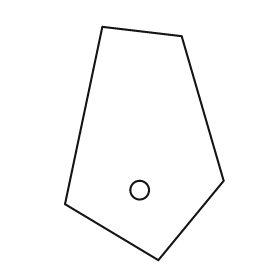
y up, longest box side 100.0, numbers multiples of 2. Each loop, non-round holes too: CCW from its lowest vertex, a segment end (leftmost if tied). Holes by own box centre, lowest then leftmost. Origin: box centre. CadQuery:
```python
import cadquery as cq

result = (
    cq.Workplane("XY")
    .moveTo(6.0, -50.0)
    .lineTo(34.0, -16.0)
    .lineTo(16.0, 46.0)
    .lineTo(-18.0, 50.0)
    .lineTo(-34.0, -26.0)
    .close()
    .moveTo(-2.0, -20.0)
    .circle(4.0)
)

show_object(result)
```